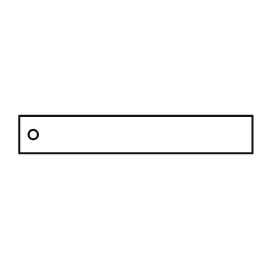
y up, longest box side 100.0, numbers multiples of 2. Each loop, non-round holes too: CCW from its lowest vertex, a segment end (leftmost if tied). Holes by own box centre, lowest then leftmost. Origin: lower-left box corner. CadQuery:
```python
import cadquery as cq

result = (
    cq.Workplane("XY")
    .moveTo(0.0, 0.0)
    .lineTo(100.0, 0.0)
    .lineTo(100.0, 16.0)
    .lineTo(0.0, 16.0)
    .close()
    .moveTo(6.0, 8.0)
    .circle(2.0)
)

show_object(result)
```